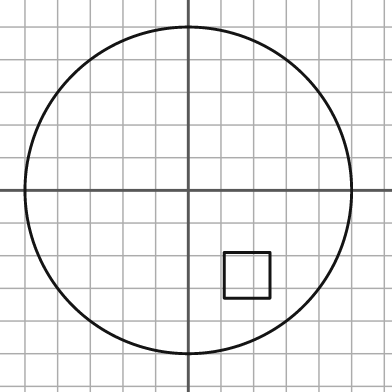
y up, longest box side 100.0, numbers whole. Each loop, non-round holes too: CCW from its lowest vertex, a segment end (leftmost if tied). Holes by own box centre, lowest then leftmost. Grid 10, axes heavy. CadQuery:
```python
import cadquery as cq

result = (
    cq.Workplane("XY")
    .moveTo(0.0, 0.0)
    .circle(50.0)
    .moveTo(11.0, -33.0)
    .lineTo(25.0, -33.0)
    .lineTo(25.0, -19.0)
    .lineTo(11.0, -19.0)
    .close()
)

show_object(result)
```